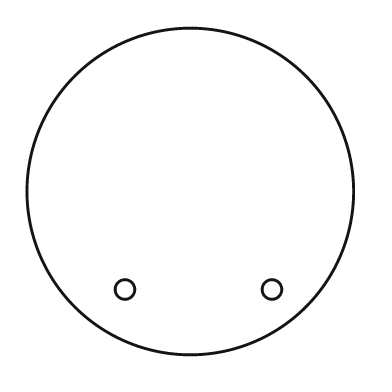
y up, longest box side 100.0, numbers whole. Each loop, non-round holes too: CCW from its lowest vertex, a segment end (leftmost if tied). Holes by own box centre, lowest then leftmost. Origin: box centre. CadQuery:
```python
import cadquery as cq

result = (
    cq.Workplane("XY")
    .moveTo(0.0, 0.0)
    .circle(50.0)
    .moveTo(-20.0, -30.0)
    .circle(3.0)
    .moveTo(25.0, -30.0)
    .circle(3.0)
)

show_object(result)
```